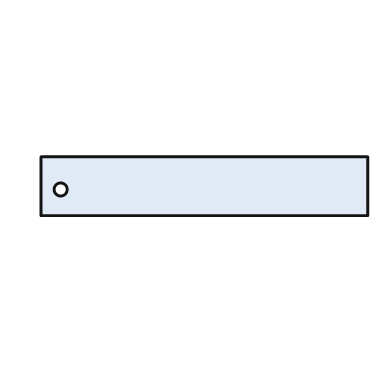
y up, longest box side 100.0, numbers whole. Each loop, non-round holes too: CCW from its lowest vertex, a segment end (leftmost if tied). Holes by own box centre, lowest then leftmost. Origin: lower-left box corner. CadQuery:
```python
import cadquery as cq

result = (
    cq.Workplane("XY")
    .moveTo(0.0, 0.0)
    .lineTo(100.0, 0.0)
    .lineTo(100.0, 18.0)
    .lineTo(0.0, 18.0)
    .close()
    .moveTo(6.0, 8.0)
    .circle(2.0)
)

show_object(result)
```